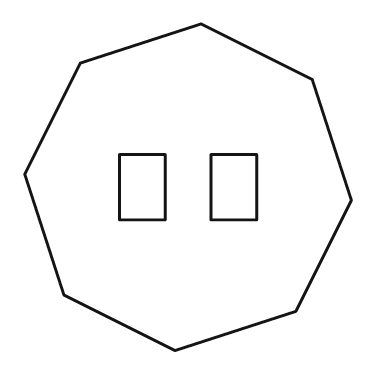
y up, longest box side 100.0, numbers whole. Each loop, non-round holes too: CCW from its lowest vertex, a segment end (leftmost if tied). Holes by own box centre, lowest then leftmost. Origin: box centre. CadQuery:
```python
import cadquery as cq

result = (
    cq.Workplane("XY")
    .moveTo(-4.0, -50.0)
    .lineTo(33.0, -38.0)
    .lineTo(50.0, -4.0)
    .lineTo(38.0, 33.0)
    .lineTo(4.0, 50.0)
    .lineTo(-33.0, 38.0)
    .lineTo(-50.0, 4.0)
    .lineTo(-38.0, -33.0)
    .close()
    .moveTo(-21.0, -10.0)
    .lineTo(-7.0, -10.0)
    .lineTo(-7.0, 10.0)
    .lineTo(-21.0, 10.0)
    .close()
    .moveTo(7.0, -10.0)
    .lineTo(21.0, -10.0)
    .lineTo(21.0, 10.0)
    .lineTo(7.0, 10.0)
    .close()
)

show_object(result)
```